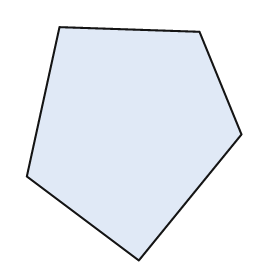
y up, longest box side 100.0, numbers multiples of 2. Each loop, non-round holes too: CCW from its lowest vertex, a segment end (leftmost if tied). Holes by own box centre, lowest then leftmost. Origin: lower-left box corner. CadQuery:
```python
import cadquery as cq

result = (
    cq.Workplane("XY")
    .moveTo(48.0, 0.0)
    .lineTo(92.0, 54.0)
    .lineTo(74.0, 98.0)
    .lineTo(14.0, 100.0)
    .lineTo(0.0, 36.0)
    .close()
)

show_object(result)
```